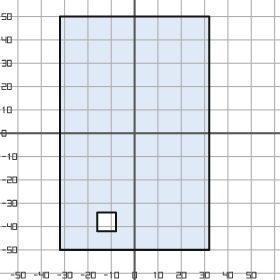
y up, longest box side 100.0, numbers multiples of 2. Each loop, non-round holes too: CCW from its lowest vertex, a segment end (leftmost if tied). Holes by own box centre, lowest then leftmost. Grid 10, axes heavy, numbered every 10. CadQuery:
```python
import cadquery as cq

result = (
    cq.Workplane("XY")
    .moveTo(-32.0, -50.0)
    .lineTo(32.0, -50.0)
    .lineTo(32.0, 50.0)
    .lineTo(-32.0, 50.0)
    .close()
    .moveTo(-16.0, -42.0)
    .lineTo(-8.0, -42.0)
    .lineTo(-8.0, -34.0)
    .lineTo(-16.0, -34.0)
    .close()
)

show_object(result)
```